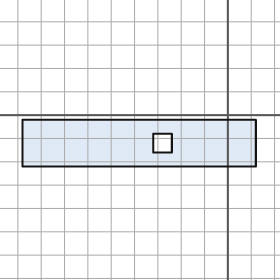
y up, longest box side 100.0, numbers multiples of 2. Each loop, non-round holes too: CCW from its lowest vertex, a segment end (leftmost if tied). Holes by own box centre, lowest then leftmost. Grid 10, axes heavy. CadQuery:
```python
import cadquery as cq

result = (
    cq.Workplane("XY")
    .moveTo(-88.0, -22.0)
    .lineTo(12.0, -22.0)
    .lineTo(12.0, -2.0)
    .lineTo(-88.0, -2.0)
    .close()
    .moveTo(-32.0, -16.0)
    .lineTo(-24.0, -16.0)
    .lineTo(-24.0, -8.0)
    .lineTo(-32.0, -8.0)
    .close()
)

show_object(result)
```